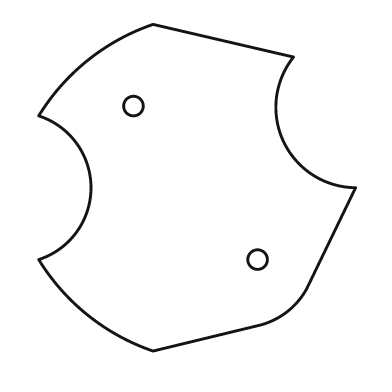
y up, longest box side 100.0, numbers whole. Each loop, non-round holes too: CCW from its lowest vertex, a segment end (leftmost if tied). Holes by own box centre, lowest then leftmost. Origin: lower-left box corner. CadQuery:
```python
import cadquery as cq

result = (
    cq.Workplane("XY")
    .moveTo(35.0, 0.0)
    .lineTo(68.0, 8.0)
    .threePointArc((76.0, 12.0), (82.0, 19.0))
    .lineTo(97.0, 50.0)
    .threePointArc((75.0, 64.0), (78.0, 90.0))
    .lineTo(35.0, 100.0)
    .threePointArc((15.0, 89.0), (0.0, 72.0))
    .threePointArc((16.0, 50.0), (0.0, 28.0))
    .threePointArc((15.0, 11.0), (35.0, 0.0))
    .close()
    .moveTo(67.0, 28.0)
    .circle(3.0)
    .moveTo(29.0, 75.0)
    .circle(3.0)
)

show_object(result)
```